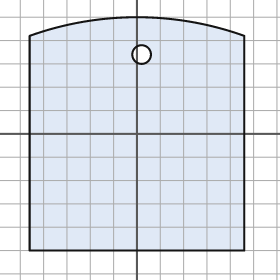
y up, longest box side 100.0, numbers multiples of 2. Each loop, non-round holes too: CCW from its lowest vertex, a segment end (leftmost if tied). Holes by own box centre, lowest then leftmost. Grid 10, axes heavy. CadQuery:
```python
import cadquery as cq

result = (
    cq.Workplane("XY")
    .moveTo(-46.0, -50.0)
    .lineTo(46.0, -50.0)
    .lineTo(46.0, 42.0)
    .threePointArc((0.0, 50.0), (-46.0, 42.0))
    .close()
    .moveTo(2.0, 34.0)
    .circle(4.0)
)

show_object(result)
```